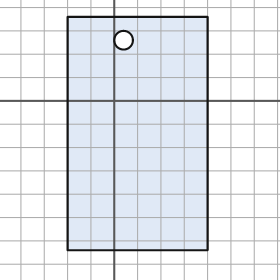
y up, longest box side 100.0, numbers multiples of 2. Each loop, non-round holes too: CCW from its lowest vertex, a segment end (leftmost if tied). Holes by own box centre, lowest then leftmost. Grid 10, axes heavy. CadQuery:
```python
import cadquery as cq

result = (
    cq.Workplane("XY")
    .moveTo(-20.0, -64.0)
    .lineTo(40.0, -64.0)
    .lineTo(40.0, 36.0)
    .lineTo(-20.0, 36.0)
    .close()
    .moveTo(4.0, 26.0)
    .circle(4.0)
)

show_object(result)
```